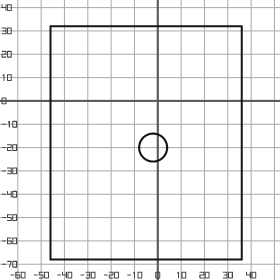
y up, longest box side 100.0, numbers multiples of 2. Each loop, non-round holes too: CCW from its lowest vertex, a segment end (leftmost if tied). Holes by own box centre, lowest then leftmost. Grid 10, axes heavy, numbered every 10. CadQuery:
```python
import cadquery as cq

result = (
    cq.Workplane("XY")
    .moveTo(-46.0, -68.0)
    .lineTo(36.0, -68.0)
    .lineTo(36.0, 32.0)
    .lineTo(-46.0, 32.0)
    .close()
    .moveTo(-2.0, -20.0)
    .circle(6.0)
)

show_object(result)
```